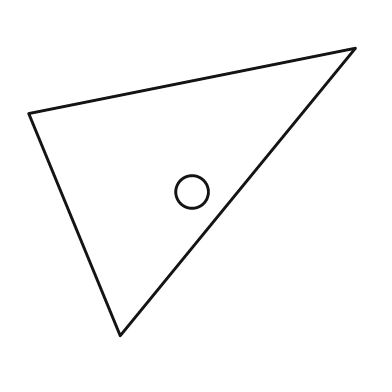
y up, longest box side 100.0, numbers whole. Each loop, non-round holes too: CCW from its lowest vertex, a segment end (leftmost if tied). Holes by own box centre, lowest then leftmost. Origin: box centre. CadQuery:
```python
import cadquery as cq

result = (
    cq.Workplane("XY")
    .moveTo(-22.0, -44.0)
    .lineTo(50.0, 44.0)
    .lineTo(-50.0, 24.0)
    .close()
    .moveTo(0.0, 0.0)
    .circle(5.0)
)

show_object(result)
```